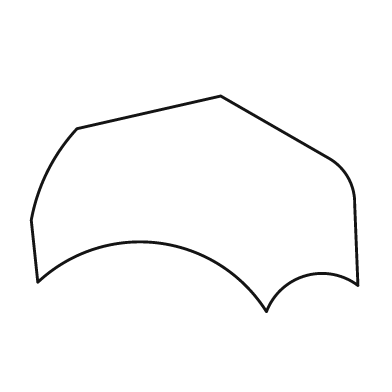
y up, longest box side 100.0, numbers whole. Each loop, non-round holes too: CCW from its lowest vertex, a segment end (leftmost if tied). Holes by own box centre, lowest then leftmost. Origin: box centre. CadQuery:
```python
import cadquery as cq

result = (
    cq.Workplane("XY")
    .moveTo(22.0, -33.0)
    .threePointArc((34.0, -22.0), (50.0, -25.0))
    .lineTo(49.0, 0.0)
    .threePointArc((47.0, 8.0), (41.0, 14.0))
    .lineTo(8.0, 33.0)
    .lineTo(-36.0, 23.0)
    .threePointArc((-45.0, 10.0), (-50.0, -5.0))
    .lineTo(-48.0, -24.0)
    .threePointArc((-11.0, -12.0), (22.0, -33.0))
    .close()
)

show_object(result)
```